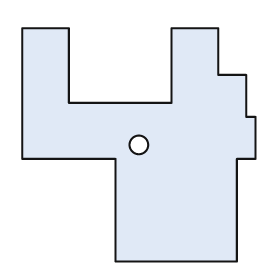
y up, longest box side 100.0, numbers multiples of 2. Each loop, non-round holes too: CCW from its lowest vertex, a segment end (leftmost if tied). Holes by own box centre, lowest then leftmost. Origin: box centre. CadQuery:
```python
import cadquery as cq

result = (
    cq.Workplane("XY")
    .moveTo(-10.0, -50.0)
    .lineTo(42.0, -50.0)
    .lineTo(42.0, -6.0)
    .lineTo(50.0, -6.0)
    .lineTo(50.0, 12.0)
    .lineTo(46.0, 12.0)
    .lineTo(46.0, 30.0)
    .lineTo(34.0, 30.0)
    .lineTo(34.0, 50.0)
    .lineTo(14.0, 50.0)
    .lineTo(14.0, 18.0)
    .lineTo(-30.0, 18.0)
    .lineTo(-30.0, 50.0)
    .lineTo(-50.0, 50.0)
    .lineTo(-50.0, -6.0)
    .lineTo(-10.0, -6.0)
    .close()
    .moveTo(0.0, 0.0)
    .circle(4.0)
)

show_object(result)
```